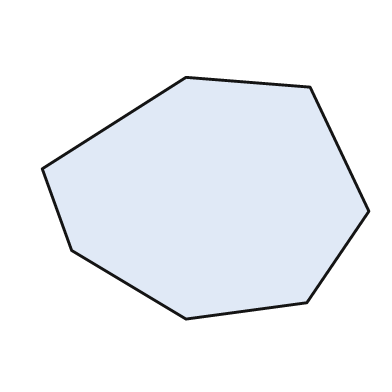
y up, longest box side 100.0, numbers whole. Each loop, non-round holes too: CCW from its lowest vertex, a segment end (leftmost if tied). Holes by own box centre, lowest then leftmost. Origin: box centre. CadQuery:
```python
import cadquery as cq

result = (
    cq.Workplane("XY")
    .moveTo(-6.0, -37.0)
    .lineTo(31.0, -32.0)
    .lineTo(50.0, -4.0)
    .lineTo(32.0, 34.0)
    .lineTo(-6.0, 37.0)
    .lineTo(-50.0, 9.0)
    .lineTo(-41.0, -16.0)
    .close()
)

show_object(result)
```